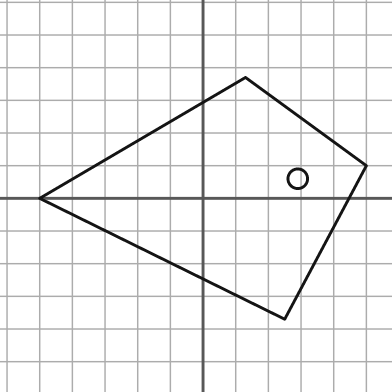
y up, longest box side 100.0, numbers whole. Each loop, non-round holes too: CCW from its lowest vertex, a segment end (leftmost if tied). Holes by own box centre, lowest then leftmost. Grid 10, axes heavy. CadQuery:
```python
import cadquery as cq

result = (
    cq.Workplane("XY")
    .moveTo(25.0, -37.0)
    .lineTo(50.0, 10.0)
    .lineTo(13.0, 37.0)
    .lineTo(-50.0, 0.0)
    .close()
    .moveTo(29.0, 6.0)
    .circle(3.0)
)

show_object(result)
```